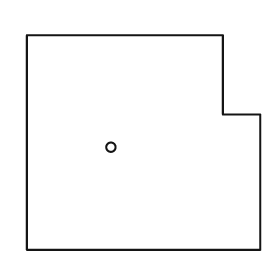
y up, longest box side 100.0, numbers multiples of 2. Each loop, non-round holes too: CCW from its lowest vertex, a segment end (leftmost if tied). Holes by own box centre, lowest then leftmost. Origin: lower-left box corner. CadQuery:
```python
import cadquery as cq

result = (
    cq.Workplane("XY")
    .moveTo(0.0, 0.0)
    .lineTo(100.0, 0.0)
    .lineTo(100.0, 58.0)
    .lineTo(84.0, 58.0)
    .lineTo(84.0, 92.0)
    .lineTo(0.0, 92.0)
    .close()
    .moveTo(36.0, 44.0)
    .circle(2.0)
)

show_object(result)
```